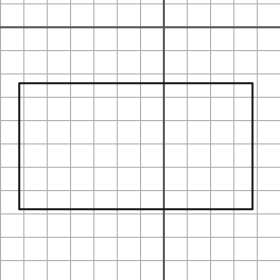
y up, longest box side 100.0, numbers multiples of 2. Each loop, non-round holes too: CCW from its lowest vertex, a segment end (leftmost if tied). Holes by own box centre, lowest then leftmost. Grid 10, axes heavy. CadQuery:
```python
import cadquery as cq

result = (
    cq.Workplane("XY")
    .moveTo(-62.0, -78.0)
    .lineTo(38.0, -78.0)
    .lineTo(38.0, -24.0)
    .lineTo(-62.0, -24.0)
    .close()
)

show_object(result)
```